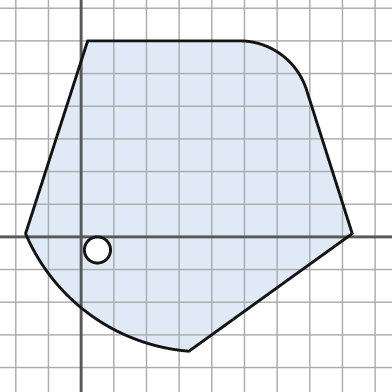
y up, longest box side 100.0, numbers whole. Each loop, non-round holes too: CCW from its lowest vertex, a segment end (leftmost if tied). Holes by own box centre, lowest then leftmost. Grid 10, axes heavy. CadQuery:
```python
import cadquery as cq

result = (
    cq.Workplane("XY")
    .moveTo(33.0, -35.0)
    .lineTo(83.0, 1.0)
    .lineTo(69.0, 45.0)
    .threePointArc((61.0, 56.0), (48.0, 60.0))
    .lineTo(2.0, 60.0)
    .lineTo(-17.0, 1.0)
    .threePointArc((3.0, -24.0), (33.0, -35.0))
    .close()
    .moveTo(5.0, -4.0)
    .circle(4.0)
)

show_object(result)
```